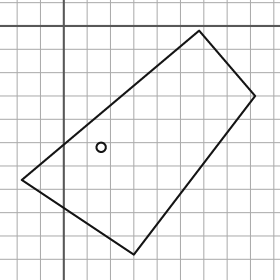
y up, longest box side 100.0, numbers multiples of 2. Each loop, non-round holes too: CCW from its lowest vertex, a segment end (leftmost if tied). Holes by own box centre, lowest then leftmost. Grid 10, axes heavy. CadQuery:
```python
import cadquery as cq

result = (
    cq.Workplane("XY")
    .moveTo(30.0, -98.0)
    .lineTo(82.0, -30.0)
    .lineTo(58.0, -2.0)
    .lineTo(-18.0, -66.0)
    .close()
    .moveTo(16.0, -52.0)
    .circle(2.0)
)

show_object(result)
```